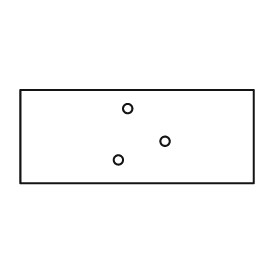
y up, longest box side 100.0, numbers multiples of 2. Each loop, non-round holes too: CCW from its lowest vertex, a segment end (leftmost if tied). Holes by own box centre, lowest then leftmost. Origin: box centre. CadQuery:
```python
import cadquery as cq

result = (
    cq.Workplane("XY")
    .moveTo(-50.0, -20.0)
    .lineTo(50.0, -20.0)
    .lineTo(50.0, 20.0)
    .lineTo(-50.0, 20.0)
    .close()
    .moveTo(-8.0, -10.0)
    .circle(2.0)
    .moveTo(12.0, -2.0)
    .circle(2.0)
    .moveTo(-4.0, 12.0)
    .circle(2.0)
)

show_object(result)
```